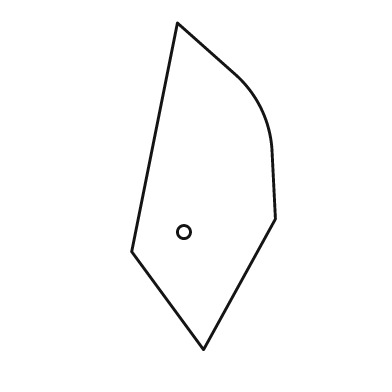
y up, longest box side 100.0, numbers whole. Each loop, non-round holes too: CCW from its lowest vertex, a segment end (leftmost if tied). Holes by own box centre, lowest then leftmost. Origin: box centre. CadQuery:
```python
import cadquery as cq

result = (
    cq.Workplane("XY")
    .moveTo(0.0, -50.0)
    .lineTo(22.0, -10.0)
    .lineTo(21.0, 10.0)
    .threePointArc((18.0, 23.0), (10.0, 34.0))
    .lineTo(-8.0, 50.0)
    .lineTo(-22.0, -20.0)
    .close()
    .moveTo(-6.0, -14.0)
    .circle(2.0)
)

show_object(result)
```